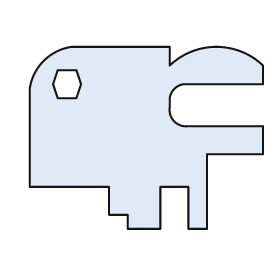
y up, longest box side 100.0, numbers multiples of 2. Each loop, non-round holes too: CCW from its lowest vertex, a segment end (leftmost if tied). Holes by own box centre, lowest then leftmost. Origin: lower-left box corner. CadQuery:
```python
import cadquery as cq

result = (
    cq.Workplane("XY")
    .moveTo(42.0, 0.0)
    .lineTo(56.0, 0.0)
    .lineTo(56.0, 18.0)
    .lineTo(68.0, 18.0)
    .lineTo(68.0, 0.0)
    .lineTo(76.0, 0.0)
    .lineTo(76.0, 32.0)
    .lineTo(100.0, 32.0)
    .lineTo(100.0, 44.0)
    .lineTo(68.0, 44.0)
    .threePointArc((62.0, 46.0), (60.0, 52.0))
    .lineTo(60.0, 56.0)
    .threePointArc((62.0, 60.0), (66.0, 62.0))
    .lineTo(100.0, 62.0)
    .lineTo(100.0, 70.0)
    .threePointArc((80.0, 78.0), (60.0, 70.0))
    .lineTo(60.0, 78.0)
    .lineTo(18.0, 78.0)
    .threePointArc((6.0, 72.0), (0.0, 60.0))
    .lineTo(0.0, 18.0)
    .lineTo(34.0, 18.0)
    .lineTo(34.0, 6.0)
    .lineTo(42.0, 6.0)
    .close()
    .moveTo(12.0, 56.0)
    .lineTo(20.0, 56.0)
    .lineTo(22.0, 62.0)
    .lineTo(20.0, 68.0)
    .lineTo(12.0, 68.0)
    .lineTo(10.0, 62.0)
    .close()
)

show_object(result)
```